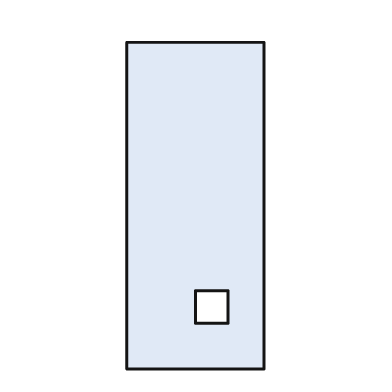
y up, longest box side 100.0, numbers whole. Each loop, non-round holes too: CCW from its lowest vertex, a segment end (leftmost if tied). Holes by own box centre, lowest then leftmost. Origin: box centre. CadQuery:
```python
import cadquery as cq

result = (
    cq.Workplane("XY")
    .moveTo(-21.0, -50.0)
    .lineTo(21.0, -50.0)
    .lineTo(21.0, 50.0)
    .lineTo(-21.0, 50.0)
    .close()
    .moveTo(0.0, -36.0)
    .lineTo(10.0, -36.0)
    .lineTo(10.0, -26.0)
    .lineTo(0.0, -26.0)
    .close()
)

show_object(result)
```